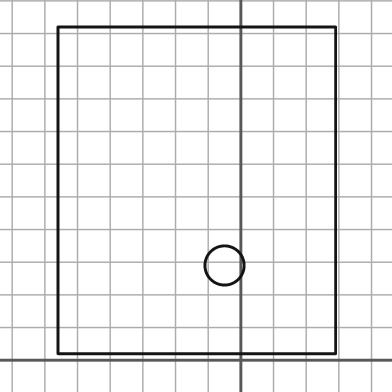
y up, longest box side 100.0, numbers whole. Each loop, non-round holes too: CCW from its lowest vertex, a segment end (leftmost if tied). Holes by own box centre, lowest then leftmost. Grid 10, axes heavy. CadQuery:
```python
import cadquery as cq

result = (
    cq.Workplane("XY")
    .moveTo(-56.0, 2.0)
    .lineTo(29.0, 2.0)
    .lineTo(29.0, 102.0)
    .lineTo(-56.0, 102.0)
    .close()
    .moveTo(-5.0, 29.0)
    .circle(6.0)
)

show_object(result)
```